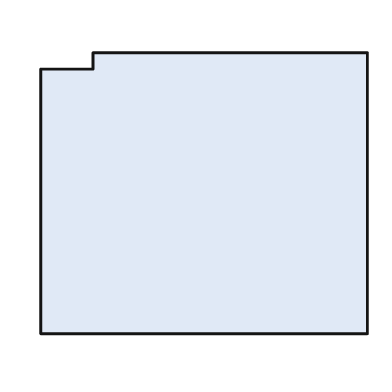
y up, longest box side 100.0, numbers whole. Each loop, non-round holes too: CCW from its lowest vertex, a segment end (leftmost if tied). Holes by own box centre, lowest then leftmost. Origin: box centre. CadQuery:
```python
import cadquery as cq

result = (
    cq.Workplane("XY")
    .moveTo(-50.0, -43.0)
    .lineTo(50.0, -43.0)
    .lineTo(50.0, 43.0)
    .lineTo(-34.0, 43.0)
    .lineTo(-34.0, 38.0)
    .lineTo(-50.0, 38.0)
    .close()
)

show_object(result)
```